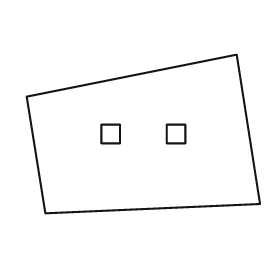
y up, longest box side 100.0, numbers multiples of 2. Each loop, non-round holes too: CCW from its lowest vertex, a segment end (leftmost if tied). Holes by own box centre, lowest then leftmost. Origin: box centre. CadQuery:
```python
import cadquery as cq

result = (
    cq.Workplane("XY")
    .moveTo(-42.0, -34.0)
    .lineTo(50.0, -30.0)
    .lineTo(40.0, 34.0)
    .lineTo(-50.0, 16.0)
    .close()
    .moveTo(-18.0, -4.0)
    .lineTo(-10.0, -4.0)
    .lineTo(-10.0, 4.0)
    .lineTo(-18.0, 4.0)
    .close()
    .moveTo(10.0, -4.0)
    .lineTo(18.0, -4.0)
    .lineTo(18.0, 4.0)
    .lineTo(10.0, 4.0)
    .close()
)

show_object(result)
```